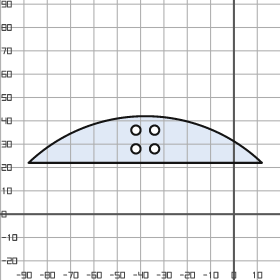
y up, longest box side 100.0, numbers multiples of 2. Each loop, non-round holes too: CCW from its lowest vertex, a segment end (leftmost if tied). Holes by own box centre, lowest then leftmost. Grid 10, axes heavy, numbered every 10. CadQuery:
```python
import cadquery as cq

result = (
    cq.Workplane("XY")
    .moveTo(-88.0, 22.0)
    .lineTo(12.0, 22.0)
    .threePointArc((-38.0, 42.0), (-88.0, 22.0))
    .close()
    .moveTo(-42.0, 28.0)
    .circle(2.0)
    .moveTo(-34.0, 28.0)
    .circle(2.0)
    .moveTo(-42.0, 36.0)
    .circle(2.0)
    .moveTo(-34.0, 36.0)
    .circle(2.0)
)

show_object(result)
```